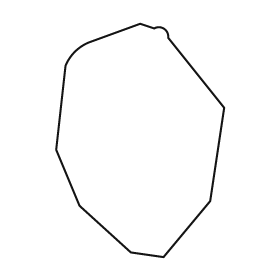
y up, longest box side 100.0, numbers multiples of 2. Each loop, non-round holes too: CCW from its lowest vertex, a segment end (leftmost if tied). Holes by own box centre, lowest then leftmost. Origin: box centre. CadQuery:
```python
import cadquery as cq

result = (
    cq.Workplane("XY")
    .moveTo(10.0, -50.0)
    .lineTo(30.0, -26.0)
    .lineTo(36.0, 14.0)
    .lineTo(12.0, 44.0)
    .threePointArc((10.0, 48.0), (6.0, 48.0))
    .lineTo(0.0, 50.0)
    .lineTo(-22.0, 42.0)
    .threePointArc((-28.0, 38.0), (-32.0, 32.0))
    .lineTo(-36.0, -4.0)
    .lineTo(-26.0, -28.0)
    .lineTo(-4.0, -48.0)
    .close()
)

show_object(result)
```